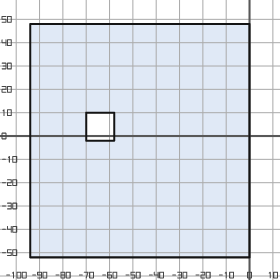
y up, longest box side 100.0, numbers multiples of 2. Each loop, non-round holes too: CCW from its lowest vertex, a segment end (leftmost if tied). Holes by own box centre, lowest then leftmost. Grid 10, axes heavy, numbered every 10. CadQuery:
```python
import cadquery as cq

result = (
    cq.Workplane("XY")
    .moveTo(-94.0, -52.0)
    .lineTo(0.0, -52.0)
    .lineTo(0.0, 48.0)
    .lineTo(-94.0, 48.0)
    .close()
    .moveTo(-70.0, -2.0)
    .lineTo(-58.0, -2.0)
    .lineTo(-58.0, 10.0)
    .lineTo(-70.0, 10.0)
    .close()
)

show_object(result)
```